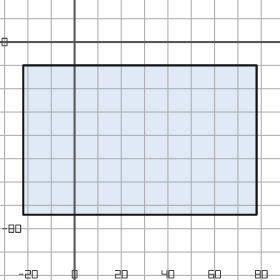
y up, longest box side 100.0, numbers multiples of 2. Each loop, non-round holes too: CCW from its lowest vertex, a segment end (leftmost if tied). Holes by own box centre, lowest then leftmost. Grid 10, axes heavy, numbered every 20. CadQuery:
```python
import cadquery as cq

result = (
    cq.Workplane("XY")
    .moveTo(-22.0, -74.0)
    .lineTo(78.0, -74.0)
    .lineTo(78.0, -10.0)
    .lineTo(-22.0, -10.0)
    .close()
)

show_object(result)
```